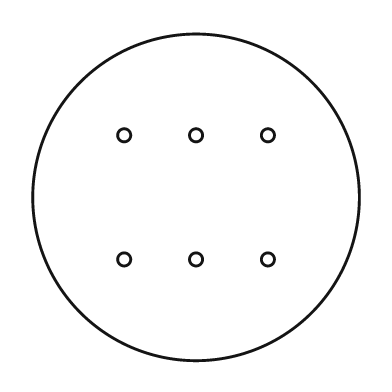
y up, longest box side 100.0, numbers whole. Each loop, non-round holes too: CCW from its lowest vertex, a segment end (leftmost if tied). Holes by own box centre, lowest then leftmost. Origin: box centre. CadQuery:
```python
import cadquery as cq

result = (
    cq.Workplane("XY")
    .moveTo(0.0, 0.0)
    .circle(50.0)
    .moveTo(-22.0, -19.0)
    .circle(2.0)
    .moveTo(0.0, -19.0)
    .circle(2.0)
    .moveTo(22.0, -19.0)
    .circle(2.0)
    .moveTo(-22.0, 19.0)
    .circle(2.0)
    .moveTo(0.0, 19.0)
    .circle(2.0)
    .moveTo(22.0, 19.0)
    .circle(2.0)
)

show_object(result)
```